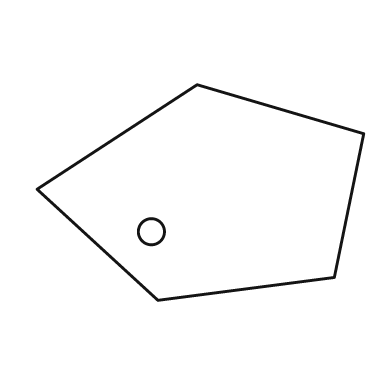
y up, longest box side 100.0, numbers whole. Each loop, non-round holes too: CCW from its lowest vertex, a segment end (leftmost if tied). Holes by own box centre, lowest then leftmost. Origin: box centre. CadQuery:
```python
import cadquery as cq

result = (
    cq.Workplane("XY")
    .moveTo(-13.0, -33.0)
    .lineTo(41.0, -26.0)
    .lineTo(50.0, 18.0)
    .lineTo(-1.0, 33.0)
    .lineTo(-50.0, 1.0)
    .close()
    .moveTo(-15.0, -12.0)
    .circle(4.0)
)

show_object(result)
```